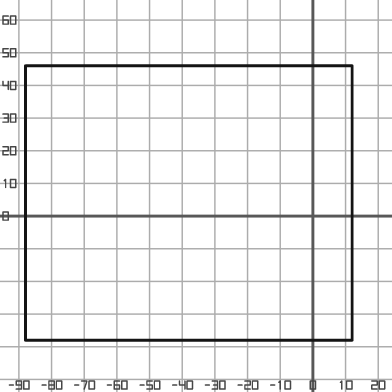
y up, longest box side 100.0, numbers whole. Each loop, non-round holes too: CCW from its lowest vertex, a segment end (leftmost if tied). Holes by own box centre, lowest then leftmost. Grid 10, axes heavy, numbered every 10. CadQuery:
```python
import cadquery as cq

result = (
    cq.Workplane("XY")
    .moveTo(-88.0, -38.0)
    .lineTo(12.0, -38.0)
    .lineTo(12.0, 46.0)
    .lineTo(-88.0, 46.0)
    .close()
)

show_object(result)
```